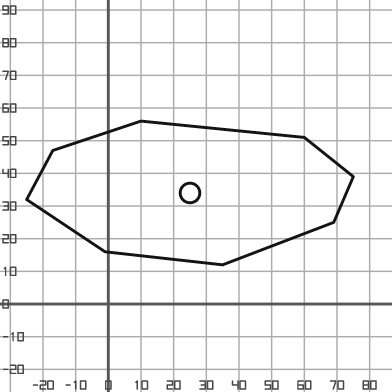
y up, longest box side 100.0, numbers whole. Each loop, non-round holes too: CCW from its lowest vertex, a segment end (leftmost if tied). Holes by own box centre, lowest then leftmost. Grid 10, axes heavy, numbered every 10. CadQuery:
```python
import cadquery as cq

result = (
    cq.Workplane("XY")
    .moveTo(35.0, 12.0)
    .lineTo(69.0, 25.0)
    .lineTo(75.0, 39.0)
    .lineTo(60.0, 51.0)
    .lineTo(10.0, 56.0)
    .lineTo(-17.0, 47.0)
    .lineTo(-25.0, 32.0)
    .lineTo(-1.0, 16.0)
    .close()
    .moveTo(25.0, 34.0)
    .circle(3.0)
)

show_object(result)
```